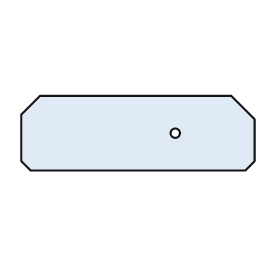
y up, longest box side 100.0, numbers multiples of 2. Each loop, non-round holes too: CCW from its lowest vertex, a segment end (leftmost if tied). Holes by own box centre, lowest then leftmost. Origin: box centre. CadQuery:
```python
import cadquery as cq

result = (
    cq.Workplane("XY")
    .moveTo(-46.0, -16.0)
    .lineTo(46.0, -16.0)
    .lineTo(50.0, -12.0)
    .lineTo(50.0, 6.0)
    .lineTo(40.0, 16.0)
    .lineTo(-42.0, 16.0)
    .lineTo(-50.0, 8.0)
    .lineTo(-50.0, -12.0)
    .close()
    .moveTo(16.0, 0.0)
    .circle(2.0)
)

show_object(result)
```